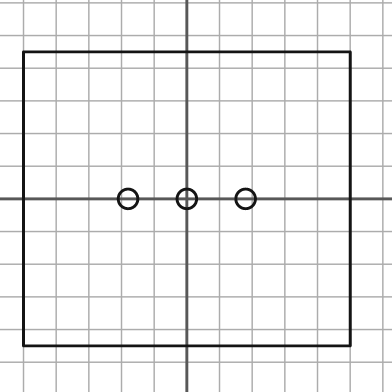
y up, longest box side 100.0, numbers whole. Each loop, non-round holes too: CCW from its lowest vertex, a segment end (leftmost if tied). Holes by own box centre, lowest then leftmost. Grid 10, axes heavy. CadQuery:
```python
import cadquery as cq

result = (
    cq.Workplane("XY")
    .moveTo(-50.0, -45.0)
    .lineTo(50.0, -45.0)
    .lineTo(50.0, 45.0)
    .lineTo(-50.0, 45.0)
    .close()
    .moveTo(-18.0, 0.0)
    .circle(3.0)
    .moveTo(0.0, 0.0)
    .circle(3.0)
    .moveTo(18.0, 0.0)
    .circle(3.0)
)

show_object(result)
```